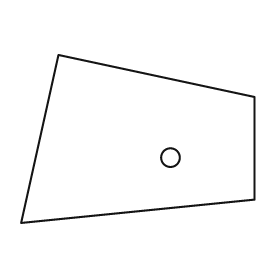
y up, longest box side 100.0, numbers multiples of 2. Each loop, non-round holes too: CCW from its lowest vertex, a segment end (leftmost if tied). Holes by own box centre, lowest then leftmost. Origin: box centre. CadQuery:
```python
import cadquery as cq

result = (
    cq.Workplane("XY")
    .moveTo(-50.0, -36.0)
    .lineTo(50.0, -26.0)
    .lineTo(50.0, 18.0)
    .lineTo(-34.0, 36.0)
    .close()
    .moveTo(14.0, -8.0)
    .circle(4.0)
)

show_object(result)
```